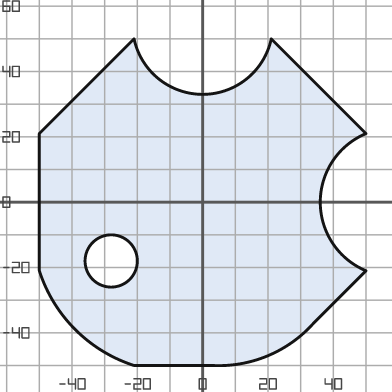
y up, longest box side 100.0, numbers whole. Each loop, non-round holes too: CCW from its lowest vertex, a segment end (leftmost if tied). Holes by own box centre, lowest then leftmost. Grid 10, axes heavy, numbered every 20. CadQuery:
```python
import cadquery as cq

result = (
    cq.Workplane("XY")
    .moveTo(-21.0, -50.0)
    .lineTo(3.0, -50.0)
    .threePointArc((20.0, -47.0), (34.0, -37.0))
    .lineTo(50.0, -21.0)
    .threePointArc((36.0, 0.0), (50.0, 21.0))
    .lineTo(21.0, 50.0)
    .threePointArc((0.0, 33.0), (-21.0, 50.0))
    .lineTo(-50.0, 21.0)
    .lineTo(-50.0, -21.0)
    .threePointArc((-39.0, -39.0), (-21.0, -50.0))
    .close()
    .moveTo(-28.0, -18.0)
    .circle(8.0)
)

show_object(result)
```